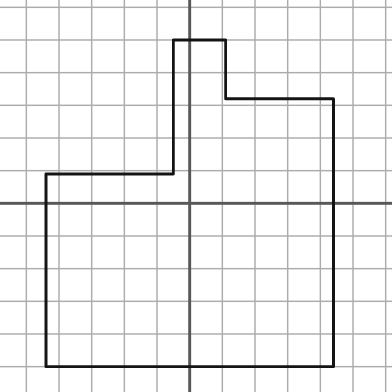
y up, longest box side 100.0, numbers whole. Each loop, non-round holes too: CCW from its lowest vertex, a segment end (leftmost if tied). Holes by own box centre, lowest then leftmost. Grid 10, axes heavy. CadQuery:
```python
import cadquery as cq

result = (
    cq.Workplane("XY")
    .moveTo(-44.0, -50.0)
    .lineTo(44.0, -50.0)
    .lineTo(44.0, 32.0)
    .lineTo(11.0, 32.0)
    .lineTo(11.0, 50.0)
    .lineTo(-5.0, 50.0)
    .lineTo(-5.0, 9.0)
    .lineTo(-44.0, 9.0)
    .close()
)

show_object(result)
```